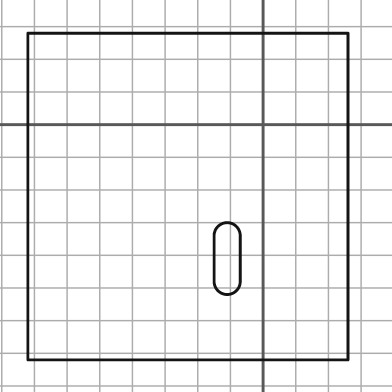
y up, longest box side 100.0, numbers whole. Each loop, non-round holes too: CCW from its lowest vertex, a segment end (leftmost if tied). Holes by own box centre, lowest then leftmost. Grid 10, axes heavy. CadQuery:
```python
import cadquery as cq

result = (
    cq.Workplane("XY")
    .moveTo(-72.0, -72.0)
    .lineTo(26.0, -72.0)
    .lineTo(26.0, 28.0)
    .lineTo(-72.0, 28.0)
    .close()
    .moveTo(-15.0, -48.0)
    .threePointArc((-11.0, -52.0), (-7.0, -48.0))
    .lineTo(-7.0, -34.0)
    .threePointArc((-11.0, -30.0), (-15.0, -34.0))
    .close()
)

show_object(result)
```